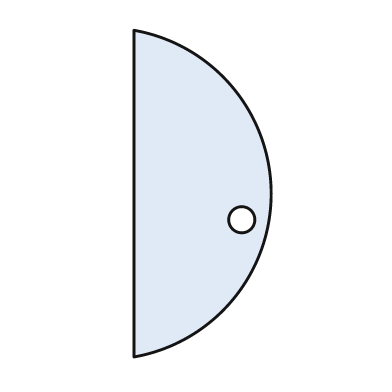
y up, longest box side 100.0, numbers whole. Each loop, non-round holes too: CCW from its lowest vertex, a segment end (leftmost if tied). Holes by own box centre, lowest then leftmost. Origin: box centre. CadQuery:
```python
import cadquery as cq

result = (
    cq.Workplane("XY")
    .moveTo(-21.0, -50.0)
    .threePointArc((21.0, 0.0), (-21.0, 50.0))
    .close()
    .moveTo(12.0, -8.0)
    .circle(4.0)
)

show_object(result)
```